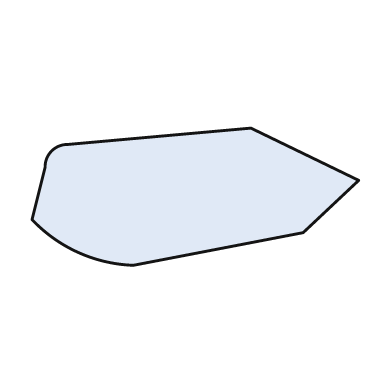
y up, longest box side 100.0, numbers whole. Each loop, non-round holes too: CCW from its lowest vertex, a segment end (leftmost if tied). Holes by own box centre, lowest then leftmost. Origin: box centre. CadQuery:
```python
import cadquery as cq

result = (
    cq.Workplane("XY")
    .moveTo(-19.0, -21.0)
    .lineTo(33.0, -11.0)
    .lineTo(50.0, 5.0)
    .lineTo(17.0, 21.0)
    .lineTo(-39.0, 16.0)
    .threePointArc((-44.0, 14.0), (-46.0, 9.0))
    .lineTo(-50.0, -7.0)
    .threePointArc((-36.0, -17.0), (-19.0, -21.0))
    .close()
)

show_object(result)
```